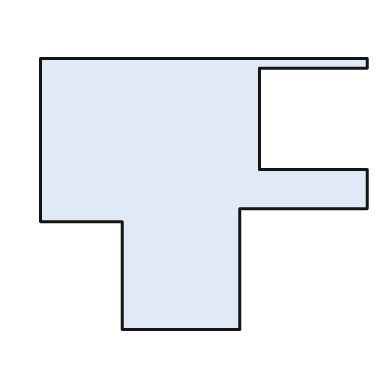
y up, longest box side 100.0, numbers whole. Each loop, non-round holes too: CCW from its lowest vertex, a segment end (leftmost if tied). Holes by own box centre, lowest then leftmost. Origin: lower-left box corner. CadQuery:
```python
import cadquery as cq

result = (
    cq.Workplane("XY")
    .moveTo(25.0, 0.0)
    .lineTo(61.0, 0.0)
    .lineTo(61.0, 37.0)
    .lineTo(100.0, 37.0)
    .lineTo(100.0, 49.0)
    .lineTo(67.0, 49.0)
    .lineTo(67.0, 80.0)
    .lineTo(100.0, 80.0)
    .lineTo(100.0, 83.0)
    .lineTo(0.0, 83.0)
    .lineTo(0.0, 33.0)
    .lineTo(25.0, 33.0)
    .close()
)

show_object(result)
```